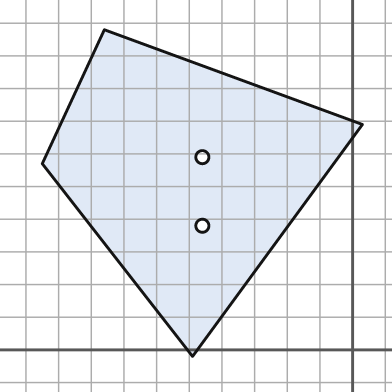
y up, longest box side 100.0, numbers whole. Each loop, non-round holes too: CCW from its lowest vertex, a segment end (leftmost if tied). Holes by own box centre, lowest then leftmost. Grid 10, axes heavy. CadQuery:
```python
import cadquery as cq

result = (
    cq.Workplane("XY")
    .moveTo(-49.0, -2.0)
    .lineTo(3.0, 69.0)
    .lineTo(-76.0, 98.0)
    .lineTo(-95.0, 57.0)
    .close()
    .moveTo(-46.0, 38.0)
    .circle(2.0)
    .moveTo(-46.0, 59.0)
    .circle(2.0)
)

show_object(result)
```